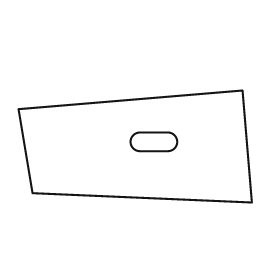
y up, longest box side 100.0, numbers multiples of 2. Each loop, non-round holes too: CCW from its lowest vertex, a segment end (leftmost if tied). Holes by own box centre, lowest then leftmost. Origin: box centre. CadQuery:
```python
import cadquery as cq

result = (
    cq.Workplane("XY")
    .moveTo(50.0, -24.0)
    .lineTo(46.0, 24.0)
    .lineTo(-50.0, 16.0)
    .lineTo(-44.0, -20.0)
    .close()
    .moveTo(2.0, -2.0)
    .lineTo(14.0, -2.0)
    .threePointArc((18.0, 2.0), (14.0, 6.0))
    .lineTo(2.0, 6.0)
    .threePointArc((-2.0, 2.0), (2.0, -2.0))
    .close()
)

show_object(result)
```